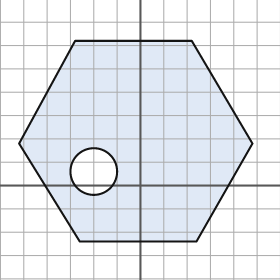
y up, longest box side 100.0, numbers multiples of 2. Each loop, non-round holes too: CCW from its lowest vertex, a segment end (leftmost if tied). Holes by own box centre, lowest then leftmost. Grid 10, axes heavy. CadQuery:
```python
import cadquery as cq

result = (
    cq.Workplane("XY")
    .moveTo(-26.0, -24.0)
    .lineTo(24.0, -24.0)
    .lineTo(48.0, 18.0)
    .lineTo(22.0, 62.0)
    .lineTo(-28.0, 62.0)
    .lineTo(-52.0, 18.0)
    .close()
    .moveTo(-20.0, 6.0)
    .circle(10.0)
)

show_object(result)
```